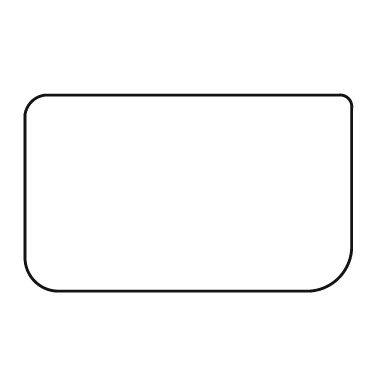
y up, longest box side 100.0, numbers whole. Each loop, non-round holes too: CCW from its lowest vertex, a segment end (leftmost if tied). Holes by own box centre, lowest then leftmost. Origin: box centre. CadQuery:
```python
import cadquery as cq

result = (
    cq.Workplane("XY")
    .moveTo(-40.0, -30.0)
    .lineTo(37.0, -30.0)
    .threePointArc((46.0, -26.0), (50.0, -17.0))
    .lineTo(50.0, 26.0)
    .threePointArc((49.0, 29.0), (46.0, 30.0))
    .lineTo(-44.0, 30.0)
    .threePointArc((-48.0, 28.0), (-50.0, 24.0))
    .lineTo(-50.0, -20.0)
    .threePointArc((-47.0, -27.0), (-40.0, -30.0))
    .close()
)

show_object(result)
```